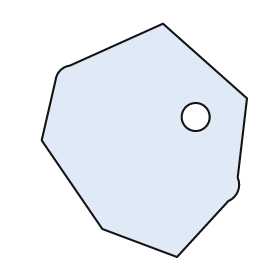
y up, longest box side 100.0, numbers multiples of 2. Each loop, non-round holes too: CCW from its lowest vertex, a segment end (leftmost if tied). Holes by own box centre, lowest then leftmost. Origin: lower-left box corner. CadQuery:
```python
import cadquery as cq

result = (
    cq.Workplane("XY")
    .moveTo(58.0, 0.0)
    .lineTo(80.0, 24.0)
    .threePointArc((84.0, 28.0), (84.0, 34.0))
    .lineTo(88.0, 68.0)
    .lineTo(52.0, 100.0)
    .lineTo(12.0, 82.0)
    .threePointArc((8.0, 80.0), (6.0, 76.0))
    .lineTo(0.0, 50.0)
    .lineTo(26.0, 12.0)
    .close()
    .moveTo(66.0, 60.0)
    .circle(6.0)
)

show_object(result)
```